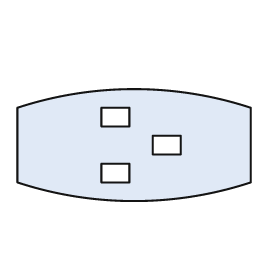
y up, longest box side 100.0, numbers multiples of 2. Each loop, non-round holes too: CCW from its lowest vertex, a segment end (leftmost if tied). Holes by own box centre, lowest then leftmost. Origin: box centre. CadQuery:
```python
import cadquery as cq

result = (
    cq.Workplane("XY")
    .moveTo(-50.0, -16.0)
    .threePointArc((0.0, -24.0), (50.0, -16.0))
    .lineTo(50.0, 16.0)
    .threePointArc((0.0, 24.0), (-50.0, 16.0))
    .close()
    .moveTo(-14.0, -16.0)
    .lineTo(-2.0, -16.0)
    .lineTo(-2.0, -8.0)
    .lineTo(-14.0, -8.0)
    .close()
    .moveTo(8.0, -4.0)
    .lineTo(20.0, -4.0)
    .lineTo(20.0, 4.0)
    .lineTo(8.0, 4.0)
    .close()
    .moveTo(-14.0, 8.0)
    .lineTo(-2.0, 8.0)
    .lineTo(-2.0, 16.0)
    .lineTo(-14.0, 16.0)
    .close()
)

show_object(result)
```